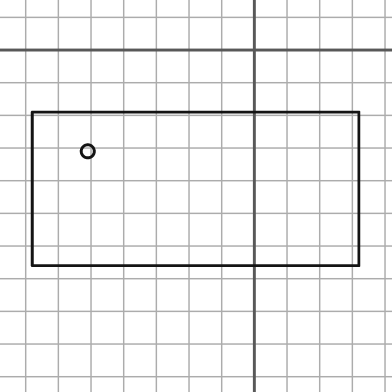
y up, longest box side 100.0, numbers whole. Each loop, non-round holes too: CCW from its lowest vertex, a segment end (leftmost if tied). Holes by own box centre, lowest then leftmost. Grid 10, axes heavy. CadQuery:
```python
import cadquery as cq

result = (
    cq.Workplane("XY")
    .moveTo(-68.0, -66.0)
    .lineTo(32.0, -66.0)
    .lineTo(32.0, -19.0)
    .lineTo(-68.0, -19.0)
    .close()
    .moveTo(-51.0, -31.0)
    .circle(2.0)
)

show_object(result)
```